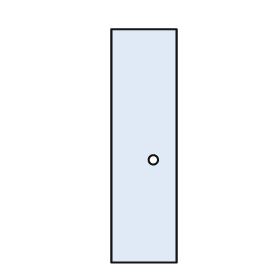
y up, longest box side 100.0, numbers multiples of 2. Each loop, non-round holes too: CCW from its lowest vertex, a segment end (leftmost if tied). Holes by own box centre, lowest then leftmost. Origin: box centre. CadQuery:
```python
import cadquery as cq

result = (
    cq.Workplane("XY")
    .moveTo(-14.0, -50.0)
    .lineTo(14.0, -50.0)
    .lineTo(14.0, 50.0)
    .lineTo(-14.0, 50.0)
    .close()
    .moveTo(4.0, -6.0)
    .circle(2.0)
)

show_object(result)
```